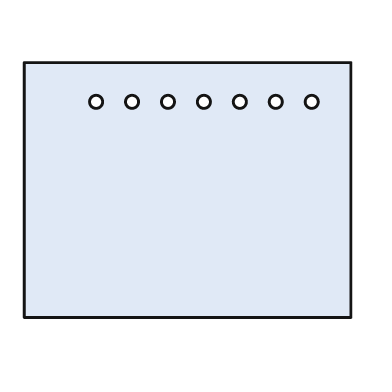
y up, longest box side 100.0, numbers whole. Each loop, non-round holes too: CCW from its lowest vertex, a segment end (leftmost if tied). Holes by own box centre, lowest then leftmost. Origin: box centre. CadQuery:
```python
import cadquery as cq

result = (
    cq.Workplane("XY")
    .moveTo(-50.0, -39.0)
    .lineTo(50.0, -39.0)
    .lineTo(50.0, 39.0)
    .lineTo(-50.0, 39.0)
    .close()
    .moveTo(-28.0, 27.0)
    .circle(2.0)
    .moveTo(-17.0, 27.0)
    .circle(2.0)
    .moveTo(-6.0, 27.0)
    .circle(2.0)
    .moveTo(5.0, 27.0)
    .circle(2.0)
    .moveTo(16.0, 27.0)
    .circle(2.0)
    .moveTo(27.0, 27.0)
    .circle(2.0)
    .moveTo(38.0, 27.0)
    .circle(2.0)
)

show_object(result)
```